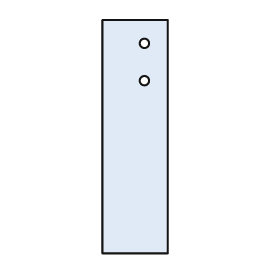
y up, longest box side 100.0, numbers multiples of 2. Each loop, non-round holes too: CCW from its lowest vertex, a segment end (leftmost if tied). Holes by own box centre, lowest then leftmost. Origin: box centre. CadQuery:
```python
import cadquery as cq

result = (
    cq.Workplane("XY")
    .moveTo(-14.0, -50.0)
    .lineTo(14.0, -50.0)
    .lineTo(14.0, 50.0)
    .lineTo(-14.0, 50.0)
    .close()
    .moveTo(4.0, 24.0)
    .circle(2.0)
    .moveTo(4.0, 40.0)
    .circle(2.0)
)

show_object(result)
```